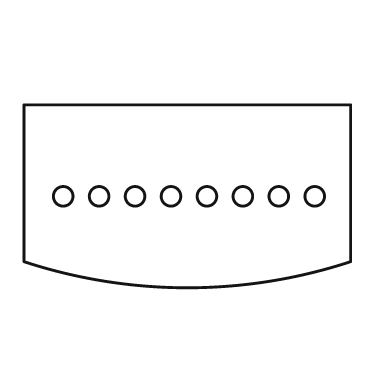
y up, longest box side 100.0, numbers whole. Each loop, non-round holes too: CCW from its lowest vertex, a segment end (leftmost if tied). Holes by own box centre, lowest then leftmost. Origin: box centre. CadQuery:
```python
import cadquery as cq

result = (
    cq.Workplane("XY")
    .moveTo(-50.0, -20.0)
    .threePointArc((0.0, -28.0), (50.0, -20.0))
    .lineTo(50.0, 28.0)
    .lineTo(-50.0, 28.0)
    .close()
    .moveTo(-38.0, 0.0)
    .circle(3.0)
    .moveTo(-27.0, 0.0)
    .circle(3.0)
    .moveTo(-16.0, 0.0)
    .circle(3.0)
    .moveTo(-5.0, 0.0)
    .circle(3.0)
    .moveTo(6.0, 0.0)
    .circle(3.0)
    .moveTo(17.0, 0.0)
    .circle(3.0)
    .moveTo(28.0, 0.0)
    .circle(3.0)
    .moveTo(39.0, 0.0)
    .circle(3.0)
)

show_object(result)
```